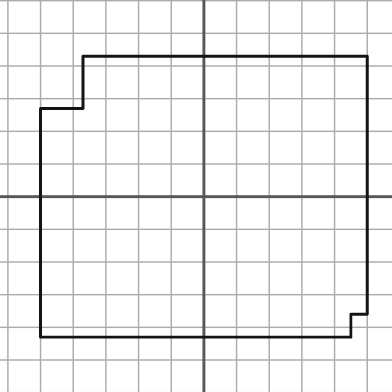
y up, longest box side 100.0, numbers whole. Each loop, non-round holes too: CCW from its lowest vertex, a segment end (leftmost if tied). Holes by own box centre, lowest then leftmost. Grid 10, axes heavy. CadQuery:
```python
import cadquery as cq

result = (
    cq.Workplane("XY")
    .moveTo(-50.0, -43.0)
    .lineTo(45.0, -43.0)
    .lineTo(45.0, -36.0)
    .lineTo(50.0, -36.0)
    .lineTo(50.0, 43.0)
    .lineTo(-37.0, 43.0)
    .lineTo(-37.0, 27.0)
    .lineTo(-50.0, 27.0)
    .close()
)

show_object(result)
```